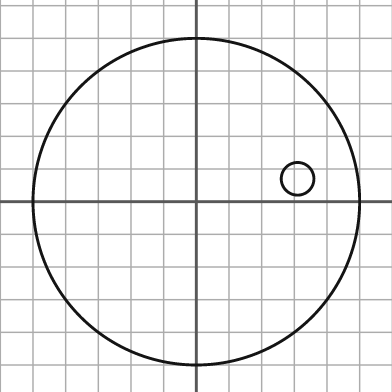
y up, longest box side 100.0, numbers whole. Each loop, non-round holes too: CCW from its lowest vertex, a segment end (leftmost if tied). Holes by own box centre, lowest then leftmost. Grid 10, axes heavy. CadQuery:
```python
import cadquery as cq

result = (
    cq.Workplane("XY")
    .moveTo(0.0, 0.0)
    .circle(50.0)
    .moveTo(31.0, 7.0)
    .circle(5.0)
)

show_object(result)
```